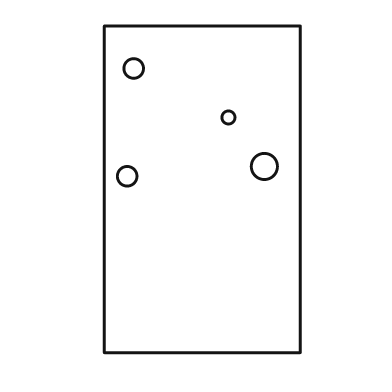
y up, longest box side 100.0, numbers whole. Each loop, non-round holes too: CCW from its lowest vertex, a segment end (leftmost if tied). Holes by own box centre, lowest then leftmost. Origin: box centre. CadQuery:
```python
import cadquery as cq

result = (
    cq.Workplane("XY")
    .moveTo(-30.0, -50.0)
    .lineTo(30.0, -50.0)
    .lineTo(30.0, 50.0)
    .lineTo(-30.0, 50.0)
    .close()
    .moveTo(-23.0, 4.0)
    .circle(3.0)
    .moveTo(19.0, 7.0)
    .circle(4.0)
    .moveTo(8.0, 22.0)
    .circle(2.0)
    .moveTo(-21.0, 37.0)
    .circle(3.0)
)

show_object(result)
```